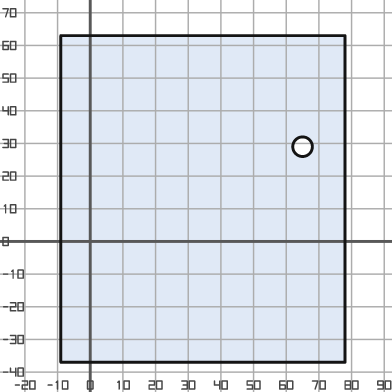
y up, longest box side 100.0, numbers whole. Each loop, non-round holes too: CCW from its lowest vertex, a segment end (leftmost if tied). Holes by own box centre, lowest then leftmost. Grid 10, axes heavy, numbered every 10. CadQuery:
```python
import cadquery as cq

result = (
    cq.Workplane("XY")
    .moveTo(-9.0, -37.0)
    .lineTo(78.0, -37.0)
    .lineTo(78.0, 63.0)
    .lineTo(-9.0, 63.0)
    .close()
    .moveTo(65.0, 29.0)
    .circle(3.0)
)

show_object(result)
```